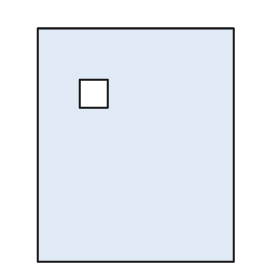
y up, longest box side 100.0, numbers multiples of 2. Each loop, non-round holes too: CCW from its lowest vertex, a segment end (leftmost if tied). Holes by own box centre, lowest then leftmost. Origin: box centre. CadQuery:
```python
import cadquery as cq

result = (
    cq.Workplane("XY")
    .moveTo(-42.0, -50.0)
    .lineTo(42.0, -50.0)
    .lineTo(42.0, 50.0)
    .lineTo(-42.0, 50.0)
    .close()
    .moveTo(-24.0, 16.0)
    .lineTo(-12.0, 16.0)
    .lineTo(-12.0, 28.0)
    .lineTo(-24.0, 28.0)
    .close()
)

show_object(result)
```